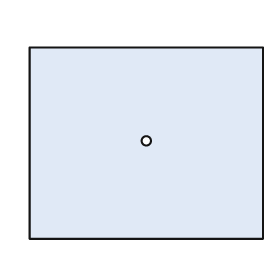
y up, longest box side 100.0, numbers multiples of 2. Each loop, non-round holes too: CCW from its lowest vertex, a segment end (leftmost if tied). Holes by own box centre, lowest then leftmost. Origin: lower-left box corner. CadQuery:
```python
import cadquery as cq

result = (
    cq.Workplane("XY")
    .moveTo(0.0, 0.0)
    .lineTo(100.0, 0.0)
    .lineTo(100.0, 82.0)
    .lineTo(0.0, 82.0)
    .close()
    .moveTo(50.0, 42.0)
    .circle(2.0)
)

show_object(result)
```